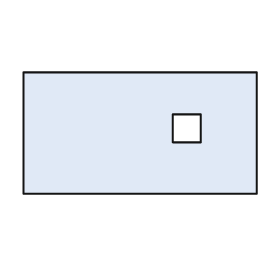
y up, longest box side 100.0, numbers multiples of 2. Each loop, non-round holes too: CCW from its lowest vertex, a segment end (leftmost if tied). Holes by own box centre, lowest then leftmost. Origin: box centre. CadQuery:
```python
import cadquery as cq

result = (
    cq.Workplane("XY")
    .moveTo(-50.0, -26.0)
    .lineTo(50.0, -26.0)
    .lineTo(50.0, 26.0)
    .lineTo(-50.0, 26.0)
    .close()
    .moveTo(14.0, -4.0)
    .lineTo(26.0, -4.0)
    .lineTo(26.0, 8.0)
    .lineTo(14.0, 8.0)
    .close()
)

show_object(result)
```